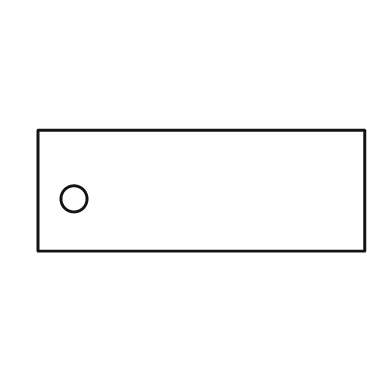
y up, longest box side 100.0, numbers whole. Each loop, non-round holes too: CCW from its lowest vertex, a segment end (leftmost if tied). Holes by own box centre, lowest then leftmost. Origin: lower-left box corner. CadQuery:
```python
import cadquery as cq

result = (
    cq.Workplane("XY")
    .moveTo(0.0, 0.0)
    .lineTo(100.0, 0.0)
    .lineTo(100.0, 37.0)
    .lineTo(0.0, 37.0)
    .close()
    .moveTo(11.0, 16.0)
    .circle(4.0)
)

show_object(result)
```